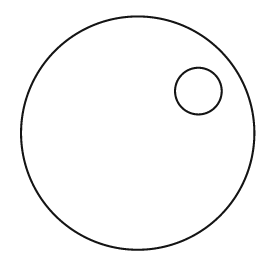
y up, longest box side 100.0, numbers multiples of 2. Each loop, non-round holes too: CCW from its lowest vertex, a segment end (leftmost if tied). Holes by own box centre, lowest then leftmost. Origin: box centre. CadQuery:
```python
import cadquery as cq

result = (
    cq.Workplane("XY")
    .moveTo(0.0, 0.0)
    .circle(50.0)
    .moveTo(26.0, 18.0)
    .circle(10.0)
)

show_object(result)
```